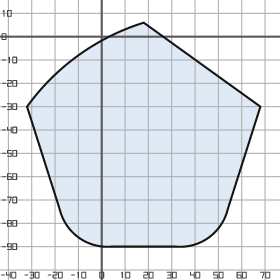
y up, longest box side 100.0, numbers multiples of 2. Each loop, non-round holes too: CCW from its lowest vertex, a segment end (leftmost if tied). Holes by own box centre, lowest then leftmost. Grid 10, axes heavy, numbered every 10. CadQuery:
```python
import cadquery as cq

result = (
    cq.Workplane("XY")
    .moveTo(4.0, -90.0)
    .lineTo(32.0, -90.0)
    .threePointArc((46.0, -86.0), (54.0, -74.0))
    .lineTo(68.0, -30.0)
    .lineTo(18.0, 6.0)
    .threePointArc((-10.0, -8.0), (-32.0, -30.0))
    .lineTo(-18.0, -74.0)
    .threePointArc((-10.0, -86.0), (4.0, -90.0))
    .close()
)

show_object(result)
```